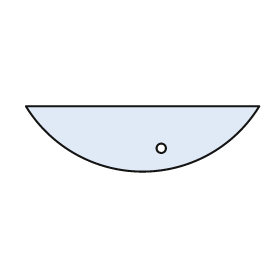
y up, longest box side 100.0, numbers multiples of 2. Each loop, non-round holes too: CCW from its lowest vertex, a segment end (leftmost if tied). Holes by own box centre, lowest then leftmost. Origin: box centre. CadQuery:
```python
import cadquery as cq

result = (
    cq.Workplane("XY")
    .moveTo(-50.0, 14.0)
    .threePointArc((0.0, -14.0), (50.0, 14.0))
    .close()
    .moveTo(8.0, -4.0)
    .circle(2.0)
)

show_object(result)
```